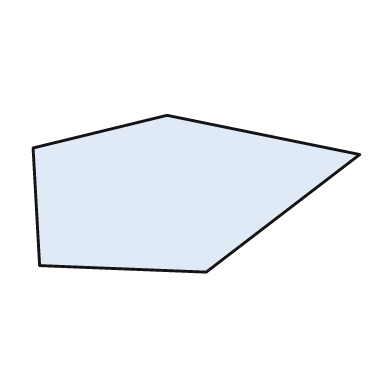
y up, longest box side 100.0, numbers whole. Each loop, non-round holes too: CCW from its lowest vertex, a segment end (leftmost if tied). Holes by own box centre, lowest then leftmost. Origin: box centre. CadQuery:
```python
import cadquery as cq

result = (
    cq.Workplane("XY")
    .moveTo(3.0, -24.0)
    .lineTo(50.0, 12.0)
    .lineTo(-9.0, 24.0)
    .lineTo(-50.0, 14.0)
    .lineTo(-48.0, -22.0)
    .close()
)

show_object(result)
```